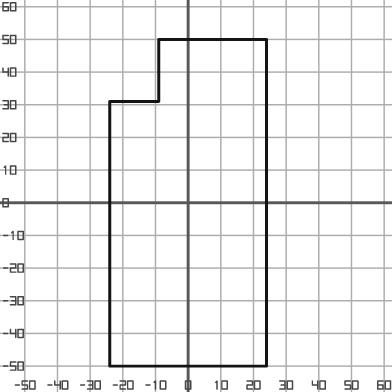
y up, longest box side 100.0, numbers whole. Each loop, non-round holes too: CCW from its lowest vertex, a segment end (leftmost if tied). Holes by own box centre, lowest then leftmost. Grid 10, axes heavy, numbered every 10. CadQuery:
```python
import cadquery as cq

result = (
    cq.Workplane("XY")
    .moveTo(-24.0, -50.0)
    .lineTo(24.0, -50.0)
    .lineTo(24.0, 50.0)
    .lineTo(-9.0, 50.0)
    .lineTo(-9.0, 31.0)
    .lineTo(-24.0, 31.0)
    .close()
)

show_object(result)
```